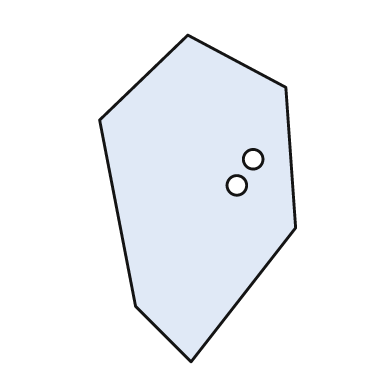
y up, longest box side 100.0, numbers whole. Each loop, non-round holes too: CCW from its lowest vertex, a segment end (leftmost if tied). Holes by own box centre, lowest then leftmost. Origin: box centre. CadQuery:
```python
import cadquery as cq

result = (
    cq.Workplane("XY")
    .moveTo(-2.0, -50.0)
    .lineTo(30.0, -9.0)
    .lineTo(27.0, 34.0)
    .lineTo(-3.0, 50.0)
    .lineTo(-30.0, 24.0)
    .lineTo(-19.0, -33.0)
    .close()
    .moveTo(12.0, 4.0)
    .circle(3.0)
    .moveTo(17.0, 12.0)
    .circle(3.0)
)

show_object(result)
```